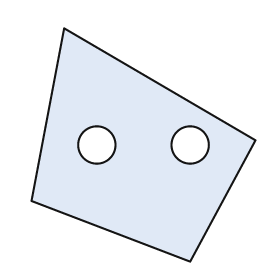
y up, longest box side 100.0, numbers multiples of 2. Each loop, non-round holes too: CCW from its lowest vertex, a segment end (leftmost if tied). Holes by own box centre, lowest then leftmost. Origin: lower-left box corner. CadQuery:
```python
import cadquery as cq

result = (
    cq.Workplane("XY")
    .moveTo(68.0, 0.0)
    .lineTo(96.0, 52.0)
    .lineTo(14.0, 100.0)
    .lineTo(0.0, 26.0)
    .close()
    .moveTo(28.0, 50.0)
    .circle(8.0)
    .moveTo(68.0, 50.0)
    .circle(8.0)
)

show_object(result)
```